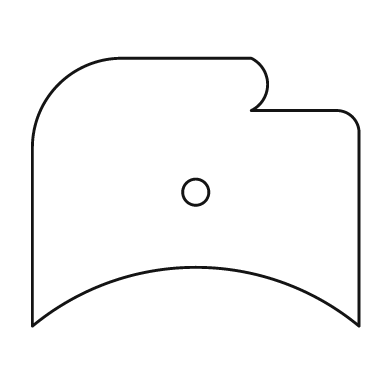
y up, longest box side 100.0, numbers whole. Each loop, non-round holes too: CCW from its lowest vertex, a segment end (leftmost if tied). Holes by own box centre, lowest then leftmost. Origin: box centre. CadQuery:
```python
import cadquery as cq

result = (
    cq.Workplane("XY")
    .moveTo(-50.0, -41.0)
    .threePointArc((0.0, -23.0), (50.0, -41.0))
    .lineTo(50.0, 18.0)
    .threePointArc((48.0, 23.0), (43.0, 25.0))
    .lineTo(17.0, 25.0)
    .threePointArc((22.0, 33.0), (17.0, 41.0))
    .lineTo(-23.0, 41.0)
    .threePointArc((-42.0, 33.0), (-50.0, 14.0))
    .close()
    .moveTo(0.0, 0.0)
    .circle(4.0)
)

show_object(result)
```